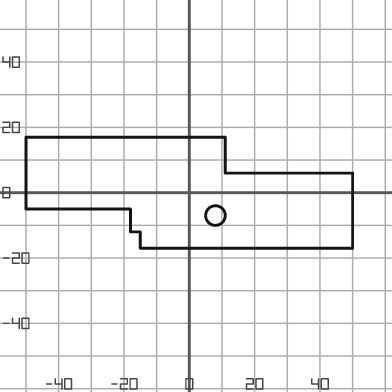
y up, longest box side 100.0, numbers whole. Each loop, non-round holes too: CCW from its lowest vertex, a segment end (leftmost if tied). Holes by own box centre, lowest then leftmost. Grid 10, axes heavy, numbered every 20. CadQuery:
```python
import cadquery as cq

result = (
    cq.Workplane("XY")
    .moveTo(-15.0, -17.0)
    .lineTo(50.0, -17.0)
    .lineTo(50.0, 6.0)
    .lineTo(11.0, 6.0)
    .lineTo(11.0, 17.0)
    .lineTo(-50.0, 17.0)
    .lineTo(-50.0, -5.0)
    .lineTo(-18.0, -5.0)
    .lineTo(-18.0, -12.0)
    .lineTo(-15.0, -12.0)
    .close()
    .moveTo(8.0, -7.0)
    .circle(3.0)
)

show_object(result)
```